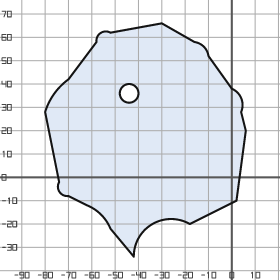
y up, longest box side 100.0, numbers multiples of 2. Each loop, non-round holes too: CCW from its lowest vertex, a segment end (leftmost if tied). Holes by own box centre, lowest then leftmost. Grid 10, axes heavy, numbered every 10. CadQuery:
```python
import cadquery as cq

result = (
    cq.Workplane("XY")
    .moveTo(-42.0, -34.0)
    .threePointArc((-34.0, -20.0), (-18.0, -20.0))
    .lineTo(2.0, -10.0)
    .lineTo(6.0, 20.0)
    .lineTo(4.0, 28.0)
    .threePointArc((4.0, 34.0), (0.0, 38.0))
    .lineTo(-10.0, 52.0)
    .threePointArc((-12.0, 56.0), (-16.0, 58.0))
    .lineTo(-30.0, 66.0)
    .lineTo(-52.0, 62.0)
    .threePointArc((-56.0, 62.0), (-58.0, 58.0))
    .lineTo(-70.0, 42.0)
    .threePointArc((-76.0, 36.0), (-80.0, 28.0))
    .lineTo(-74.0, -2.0)
    .threePointArc((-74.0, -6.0), (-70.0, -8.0))
    .lineTo(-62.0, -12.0)
    .threePointArc((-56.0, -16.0), (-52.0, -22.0))
    .close()
    .moveTo(-44.0, 36.0)
    .circle(4.0)
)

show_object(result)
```